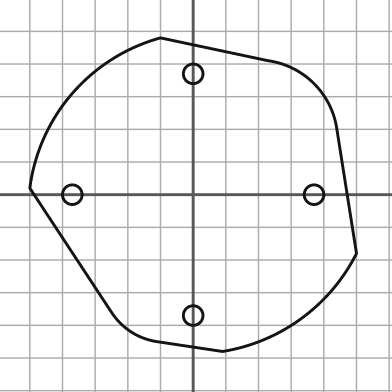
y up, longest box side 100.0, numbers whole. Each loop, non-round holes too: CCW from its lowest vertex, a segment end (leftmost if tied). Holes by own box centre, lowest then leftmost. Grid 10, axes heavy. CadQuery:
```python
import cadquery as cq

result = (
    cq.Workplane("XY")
    .moveTo(9.0, -48.0)
    .threePointArc((33.0, -38.0), (50.0, -18.0))
    .lineTo(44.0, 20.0)
    .threePointArc((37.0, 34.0), (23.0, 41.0))
    .lineTo(-10.0, 48.0)
    .threePointArc((-37.0, 31.0), (-50.0, 2.0))
    .lineTo(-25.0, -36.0)
    .threePointArc((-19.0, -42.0), (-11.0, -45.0))
    .close()
    .moveTo(0.0, -37.0)
    .circle(3.0)
    .moveTo(-37.0, 0.0)
    .circle(3.0)
    .moveTo(37.0, 0.0)
    .circle(3.0)
    .moveTo(0.0, 37.0)
    .circle(3.0)
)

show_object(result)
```